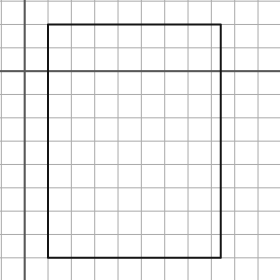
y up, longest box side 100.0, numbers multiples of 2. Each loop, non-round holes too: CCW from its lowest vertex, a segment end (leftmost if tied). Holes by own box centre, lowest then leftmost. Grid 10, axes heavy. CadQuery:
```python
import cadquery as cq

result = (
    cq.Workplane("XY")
    .moveTo(10.0, -80.0)
    .lineTo(84.0, -80.0)
    .lineTo(84.0, 20.0)
    .lineTo(10.0, 20.0)
    .close()
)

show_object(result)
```